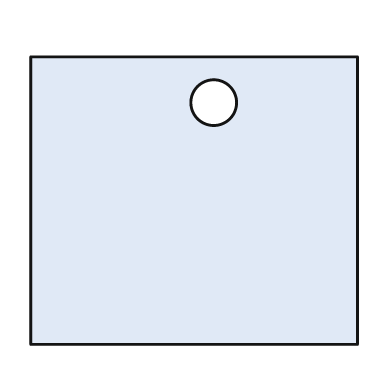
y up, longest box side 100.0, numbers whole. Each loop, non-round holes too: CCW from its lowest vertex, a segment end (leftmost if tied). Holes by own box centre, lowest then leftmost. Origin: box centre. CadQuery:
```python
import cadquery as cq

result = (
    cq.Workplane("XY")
    .moveTo(-50.0, -44.0)
    .lineTo(50.0, -44.0)
    .lineTo(50.0, 44.0)
    .lineTo(-50.0, 44.0)
    .close()
    .moveTo(6.0, 30.0)
    .circle(7.0)
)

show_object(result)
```